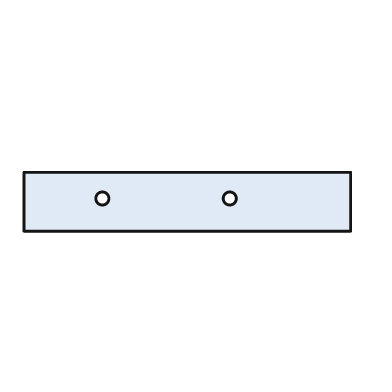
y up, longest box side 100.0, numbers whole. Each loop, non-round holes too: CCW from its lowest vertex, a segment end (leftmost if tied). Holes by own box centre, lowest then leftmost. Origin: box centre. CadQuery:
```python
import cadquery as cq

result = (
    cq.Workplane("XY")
    .moveTo(-50.0, -9.0)
    .lineTo(50.0, -9.0)
    .lineTo(50.0, 9.0)
    .lineTo(-50.0, 9.0)
    .close()
    .moveTo(-26.0, 1.0)
    .circle(2.0)
    .moveTo(13.0, 1.0)
    .circle(2.0)
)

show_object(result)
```